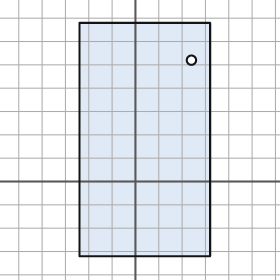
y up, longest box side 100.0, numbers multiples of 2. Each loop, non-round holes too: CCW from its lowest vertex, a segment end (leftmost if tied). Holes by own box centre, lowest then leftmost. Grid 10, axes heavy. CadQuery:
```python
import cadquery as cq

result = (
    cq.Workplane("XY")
    .moveTo(-24.0, -32.0)
    .lineTo(32.0, -32.0)
    .lineTo(32.0, 68.0)
    .lineTo(-24.0, 68.0)
    .close()
    .moveTo(24.0, 52.0)
    .circle(2.0)
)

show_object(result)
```